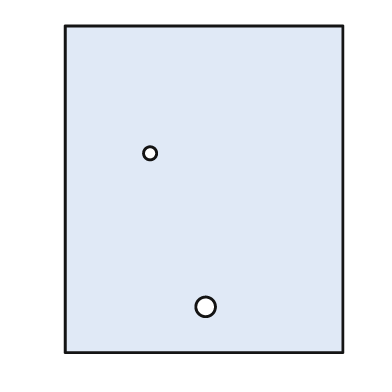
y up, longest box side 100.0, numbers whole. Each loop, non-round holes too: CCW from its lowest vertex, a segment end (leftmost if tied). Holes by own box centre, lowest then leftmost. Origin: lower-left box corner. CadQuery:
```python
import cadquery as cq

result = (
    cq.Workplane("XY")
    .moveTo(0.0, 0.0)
    .lineTo(85.0, 0.0)
    .lineTo(85.0, 100.0)
    .lineTo(0.0, 100.0)
    .close()
    .moveTo(43.0, 14.0)
    .circle(3.0)
    .moveTo(26.0, 61.0)
    .circle(2.0)
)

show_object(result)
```